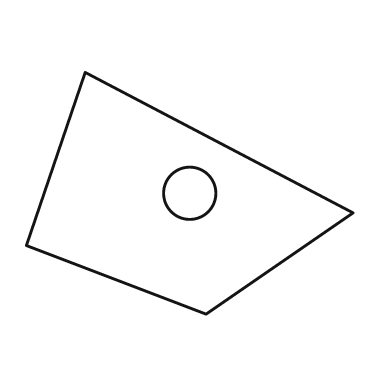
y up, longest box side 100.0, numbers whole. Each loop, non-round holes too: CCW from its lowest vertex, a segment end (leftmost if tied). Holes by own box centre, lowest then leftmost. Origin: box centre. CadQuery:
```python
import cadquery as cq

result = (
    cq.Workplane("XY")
    .moveTo(5.0, -37.0)
    .lineTo(50.0, -6.0)
    .lineTo(-32.0, 37.0)
    .lineTo(-50.0, -16.0)
    .close()
    .moveTo(0.0, 0.0)
    .circle(8.0)
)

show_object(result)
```